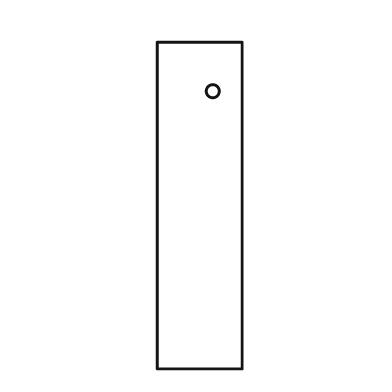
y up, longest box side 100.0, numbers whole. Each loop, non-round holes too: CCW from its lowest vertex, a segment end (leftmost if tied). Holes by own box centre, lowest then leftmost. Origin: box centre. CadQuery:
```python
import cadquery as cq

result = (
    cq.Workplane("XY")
    .moveTo(-13.0, -50.0)
    .lineTo(13.0, -50.0)
    .lineTo(13.0, 50.0)
    .lineTo(-13.0, 50.0)
    .close()
    .moveTo(4.0, 35.0)
    .circle(2.0)
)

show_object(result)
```